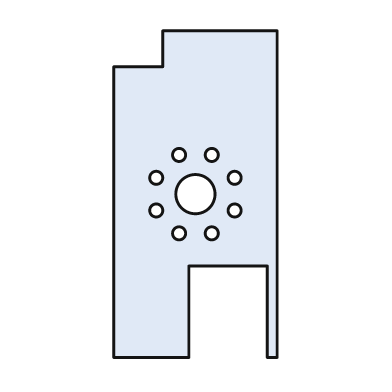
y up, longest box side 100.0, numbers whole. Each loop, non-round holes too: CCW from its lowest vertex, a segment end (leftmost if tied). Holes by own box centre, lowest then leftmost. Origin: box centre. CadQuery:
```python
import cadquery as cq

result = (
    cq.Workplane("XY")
    .moveTo(-25.0, -50.0)
    .lineTo(-2.0, -50.0)
    .lineTo(-2.0, -22.0)
    .lineTo(22.0, -22.0)
    .lineTo(22.0, -50.0)
    .lineTo(25.0, -50.0)
    .lineTo(25.0, 50.0)
    .lineTo(-10.0, 50.0)
    .lineTo(-10.0, 39.0)
    .lineTo(-25.0, 39.0)
    .close()
    .moveTo(-5.0, -12.0)
    .circle(2.0)
    .moveTo(5.0, -12.0)
    .circle(2.0)
    .moveTo(-12.0, -5.0)
    .circle(2.0)
    .moveTo(12.0, -5.0)
    .circle(2.0)
    .moveTo(0.0, 0.0)
    .circle(6.0)
    .moveTo(-12.0, 5.0)
    .circle(2.0)
    .moveTo(12.0, 5.0)
    .circle(2.0)
    .moveTo(-5.0, 12.0)
    .circle(2.0)
    .moveTo(5.0, 12.0)
    .circle(2.0)
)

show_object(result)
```